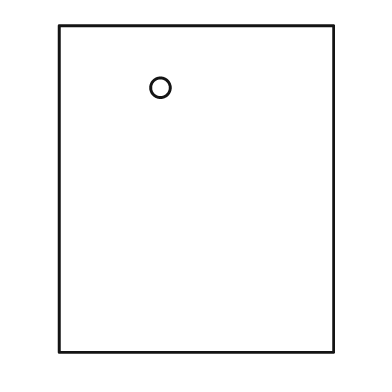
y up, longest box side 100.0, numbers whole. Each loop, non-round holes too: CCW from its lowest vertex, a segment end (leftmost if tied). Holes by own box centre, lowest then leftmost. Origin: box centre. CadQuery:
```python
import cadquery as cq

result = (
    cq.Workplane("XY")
    .moveTo(-42.0, -50.0)
    .lineTo(42.0, -50.0)
    .lineTo(42.0, 50.0)
    .lineTo(-42.0, 50.0)
    .close()
    .moveTo(-11.0, 31.0)
    .circle(3.0)
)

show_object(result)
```